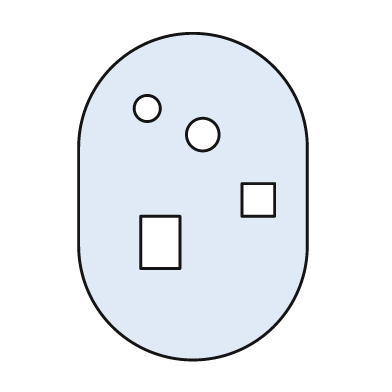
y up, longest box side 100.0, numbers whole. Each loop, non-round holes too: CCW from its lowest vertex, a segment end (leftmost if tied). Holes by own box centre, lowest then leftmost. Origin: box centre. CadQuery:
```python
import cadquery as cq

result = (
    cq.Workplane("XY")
    .moveTo(-35.0, -15.0)
    .threePointArc((0.0, -50.0), (35.0, -15.0))
    .lineTo(35.0, 15.0)
    .threePointArc((0.0, 50.0), (-35.0, 15.0))
    .close()
    .moveTo(-16.0, -22.0)
    .lineTo(-4.0, -22.0)
    .lineTo(-4.0, -6.0)
    .lineTo(-16.0, -6.0)
    .close()
    .moveTo(15.0, -6.0)
    .lineTo(25.0, -6.0)
    .lineTo(25.0, 4.0)
    .lineTo(15.0, 4.0)
    .close()
    .moveTo(3.0, 19.0)
    .circle(5.0)
    .moveTo(-14.0, 27.0)
    .circle(4.0)
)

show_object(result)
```